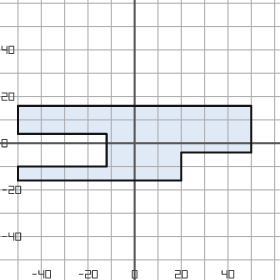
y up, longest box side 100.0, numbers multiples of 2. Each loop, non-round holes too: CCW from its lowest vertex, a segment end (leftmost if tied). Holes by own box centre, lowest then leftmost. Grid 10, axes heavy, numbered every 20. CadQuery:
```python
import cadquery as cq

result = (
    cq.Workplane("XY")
    .moveTo(-50.0, -16.0)
    .lineTo(20.0, -16.0)
    .lineTo(20.0, -4.0)
    .lineTo(50.0, -4.0)
    .lineTo(50.0, 16.0)
    .lineTo(-50.0, 16.0)
    .lineTo(-50.0, 4.0)
    .lineTo(-12.0, 4.0)
    .lineTo(-12.0, -10.0)
    .lineTo(-50.0, -10.0)
    .close()
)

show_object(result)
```